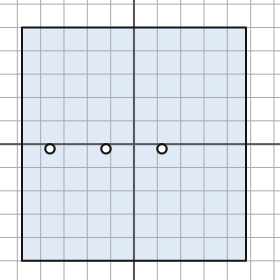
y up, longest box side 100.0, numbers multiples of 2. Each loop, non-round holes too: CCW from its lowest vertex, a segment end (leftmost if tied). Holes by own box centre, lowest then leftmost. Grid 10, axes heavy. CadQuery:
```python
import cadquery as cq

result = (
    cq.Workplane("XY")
    .moveTo(-48.0, -50.0)
    .lineTo(48.0, -50.0)
    .lineTo(48.0, 50.0)
    .lineTo(-48.0, 50.0)
    .close()
    .moveTo(-36.0, -2.0)
    .circle(2.0)
    .moveTo(-12.0, -2.0)
    .circle(2.0)
    .moveTo(12.0, -2.0)
    .circle(2.0)
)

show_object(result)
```